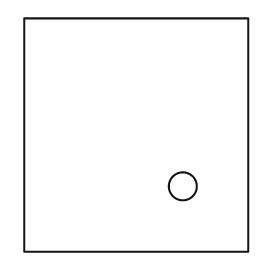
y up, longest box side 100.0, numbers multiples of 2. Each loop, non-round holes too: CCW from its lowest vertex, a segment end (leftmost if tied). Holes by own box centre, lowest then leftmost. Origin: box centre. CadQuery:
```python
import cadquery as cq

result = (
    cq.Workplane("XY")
    .moveTo(-48.0, -50.0)
    .lineTo(48.0, -50.0)
    .lineTo(48.0, 50.0)
    .lineTo(-48.0, 50.0)
    .close()
    .moveTo(20.0, -22.0)
    .circle(6.0)
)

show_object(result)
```